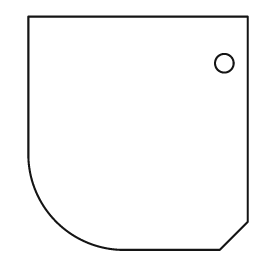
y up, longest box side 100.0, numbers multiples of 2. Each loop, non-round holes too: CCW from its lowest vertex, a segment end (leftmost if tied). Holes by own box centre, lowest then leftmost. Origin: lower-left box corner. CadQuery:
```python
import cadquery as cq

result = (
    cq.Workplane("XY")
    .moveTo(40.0, 0.0)
    .lineTo(82.0, 0.0)
    .lineTo(94.0, 12.0)
    .lineTo(94.0, 100.0)
    .lineTo(0.0, 100.0)
    .lineTo(0.0, 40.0)
    .threePointArc((12.0, 12.0), (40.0, 0.0))
    .close()
    .moveTo(84.0, 80.0)
    .circle(4.0)
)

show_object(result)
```